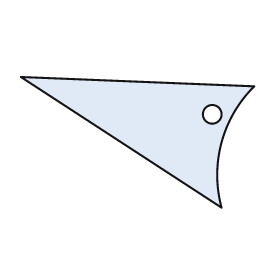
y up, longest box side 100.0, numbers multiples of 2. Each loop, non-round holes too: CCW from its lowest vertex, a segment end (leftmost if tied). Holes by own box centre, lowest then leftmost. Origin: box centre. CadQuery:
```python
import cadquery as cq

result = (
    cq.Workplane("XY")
    .moveTo(36.0, -28.0)
    .threePointArc((36.0, 0.0), (50.0, 24.0))
    .lineTo(-50.0, 28.0)
    .close()
    .moveTo(32.0, 12.0)
    .circle(4.0)
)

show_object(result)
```